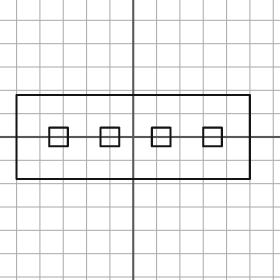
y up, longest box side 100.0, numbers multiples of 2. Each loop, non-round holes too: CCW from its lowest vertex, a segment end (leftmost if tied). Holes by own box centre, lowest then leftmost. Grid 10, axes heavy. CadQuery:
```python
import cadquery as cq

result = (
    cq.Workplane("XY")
    .moveTo(-50.0, -18.0)
    .lineTo(50.0, -18.0)
    .lineTo(50.0, 18.0)
    .lineTo(-50.0, 18.0)
    .close()
    .moveTo(-36.0, -4.0)
    .lineTo(-28.0, -4.0)
    .lineTo(-28.0, 4.0)
    .lineTo(-36.0, 4.0)
    .close()
    .moveTo(-14.0, -4.0)
    .lineTo(-6.0, -4.0)
    .lineTo(-6.0, 4.0)
    .lineTo(-14.0, 4.0)
    .close()
    .moveTo(8.0, -4.0)
    .lineTo(16.0, -4.0)
    .lineTo(16.0, 4.0)
    .lineTo(8.0, 4.0)
    .close()
    .moveTo(30.0, -4.0)
    .lineTo(38.0, -4.0)
    .lineTo(38.0, 4.0)
    .lineTo(30.0, 4.0)
    .close()
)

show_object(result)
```